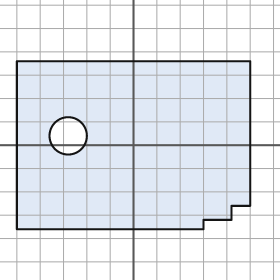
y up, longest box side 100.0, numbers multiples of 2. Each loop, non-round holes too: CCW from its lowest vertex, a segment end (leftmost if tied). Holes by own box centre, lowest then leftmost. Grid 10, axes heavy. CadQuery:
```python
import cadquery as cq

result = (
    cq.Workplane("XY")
    .moveTo(-50.0, -36.0)
    .lineTo(30.0, -36.0)
    .lineTo(30.0, -32.0)
    .lineTo(42.0, -32.0)
    .lineTo(42.0, -26.0)
    .lineTo(50.0, -26.0)
    .lineTo(50.0, 36.0)
    .lineTo(-50.0, 36.0)
    .close()
    .moveTo(-28.0, 4.0)
    .circle(8.0)
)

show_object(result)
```